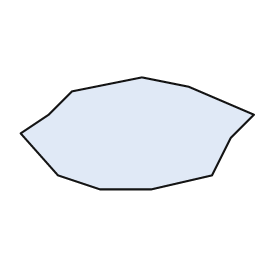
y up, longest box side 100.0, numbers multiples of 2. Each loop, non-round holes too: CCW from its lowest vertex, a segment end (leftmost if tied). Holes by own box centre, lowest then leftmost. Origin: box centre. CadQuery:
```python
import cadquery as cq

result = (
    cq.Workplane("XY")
    .moveTo(-16.0, -24.0)
    .lineTo(6.0, -24.0)
    .lineTo(32.0, -18.0)
    .lineTo(40.0, -2.0)
    .lineTo(50.0, 8.0)
    .lineTo(22.0, 20.0)
    .lineTo(2.0, 24.0)
    .lineTo(-28.0, 18.0)
    .lineTo(-38.0, 8.0)
    .lineTo(-50.0, 0.0)
    .lineTo(-34.0, -18.0)
    .close()
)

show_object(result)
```